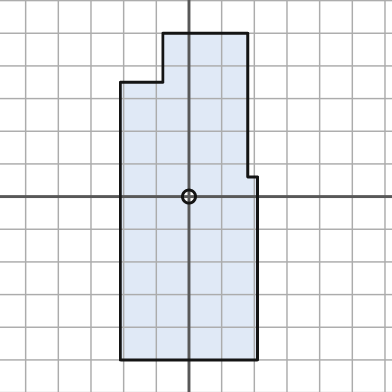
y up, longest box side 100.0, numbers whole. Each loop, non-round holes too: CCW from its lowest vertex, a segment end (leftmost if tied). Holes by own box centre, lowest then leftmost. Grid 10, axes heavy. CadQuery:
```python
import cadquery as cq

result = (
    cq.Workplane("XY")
    .moveTo(-21.0, -50.0)
    .lineTo(21.0, -50.0)
    .lineTo(21.0, 6.0)
    .lineTo(18.0, 6.0)
    .lineTo(18.0, 50.0)
    .lineTo(-8.0, 50.0)
    .lineTo(-8.0, 35.0)
    .lineTo(-21.0, 35.0)
    .close()
    .moveTo(0.0, 0.0)
    .circle(2.0)
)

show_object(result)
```